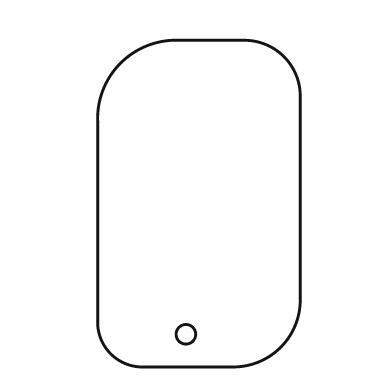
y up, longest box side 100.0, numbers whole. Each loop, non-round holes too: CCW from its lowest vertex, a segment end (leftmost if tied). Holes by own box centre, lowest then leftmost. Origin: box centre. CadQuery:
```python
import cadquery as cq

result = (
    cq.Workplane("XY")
    .moveTo(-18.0, -50.0)
    .lineTo(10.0, -50.0)
    .threePointArc((25.0, -44.0), (31.0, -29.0))
    .lineTo(31.0, 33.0)
    .threePointArc((26.0, 45.0), (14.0, 50.0))
    .lineTo(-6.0, 50.0)
    .threePointArc((-24.0, 43.0), (-31.0, 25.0))
    .lineTo(-31.0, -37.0)
    .threePointArc((-27.0, -46.0), (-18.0, -50.0))
    .close()
    .moveTo(-4.0, -40.0)
    .circle(3.0)
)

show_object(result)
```